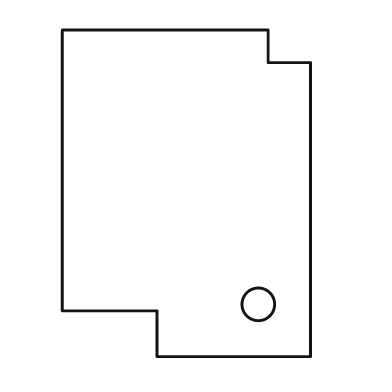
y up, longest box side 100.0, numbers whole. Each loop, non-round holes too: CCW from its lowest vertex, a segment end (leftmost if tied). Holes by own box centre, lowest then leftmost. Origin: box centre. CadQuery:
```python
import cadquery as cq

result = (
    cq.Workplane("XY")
    .moveTo(-9.0, -50.0)
    .lineTo(38.0, -50.0)
    .lineTo(38.0, 40.0)
    .lineTo(25.0, 40.0)
    .lineTo(25.0, 50.0)
    .lineTo(-38.0, 50.0)
    .lineTo(-38.0, -36.0)
    .lineTo(-9.0, -36.0)
    .close()
    .moveTo(22.0, -34.0)
    .circle(5.0)
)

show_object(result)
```